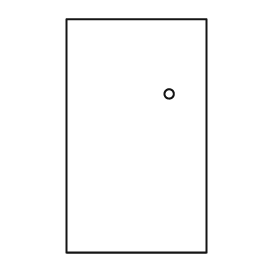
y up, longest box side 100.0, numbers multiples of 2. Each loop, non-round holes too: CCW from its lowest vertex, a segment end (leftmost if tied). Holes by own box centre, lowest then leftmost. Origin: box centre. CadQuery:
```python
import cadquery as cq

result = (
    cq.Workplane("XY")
    .moveTo(-30.0, -50.0)
    .lineTo(30.0, -50.0)
    .lineTo(30.0, 50.0)
    .lineTo(-30.0, 50.0)
    .close()
    .moveTo(14.0, 18.0)
    .circle(2.0)
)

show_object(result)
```